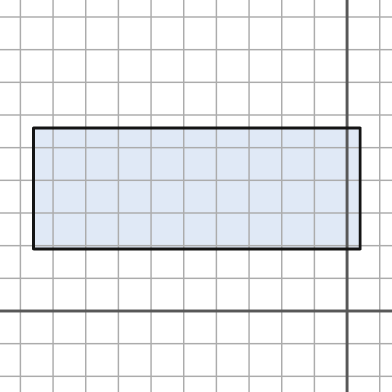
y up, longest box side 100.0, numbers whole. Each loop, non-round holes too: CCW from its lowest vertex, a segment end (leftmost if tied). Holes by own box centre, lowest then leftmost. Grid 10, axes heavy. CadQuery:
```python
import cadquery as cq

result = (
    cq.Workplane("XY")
    .moveTo(-96.0, 19.0)
    .lineTo(4.0, 19.0)
    .lineTo(4.0, 56.0)
    .lineTo(-96.0, 56.0)
    .close()
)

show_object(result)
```